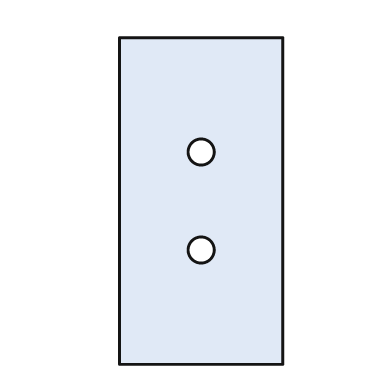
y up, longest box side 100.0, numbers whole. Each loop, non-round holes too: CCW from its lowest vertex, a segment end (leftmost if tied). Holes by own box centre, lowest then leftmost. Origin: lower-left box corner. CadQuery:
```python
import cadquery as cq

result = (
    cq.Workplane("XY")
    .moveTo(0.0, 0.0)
    .lineTo(50.0, 0.0)
    .lineTo(50.0, 100.0)
    .lineTo(0.0, 100.0)
    .close()
    .moveTo(25.0, 35.0)
    .circle(4.0)
    .moveTo(25.0, 65.0)
    .circle(4.0)
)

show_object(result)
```